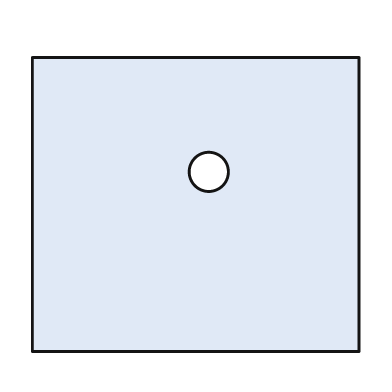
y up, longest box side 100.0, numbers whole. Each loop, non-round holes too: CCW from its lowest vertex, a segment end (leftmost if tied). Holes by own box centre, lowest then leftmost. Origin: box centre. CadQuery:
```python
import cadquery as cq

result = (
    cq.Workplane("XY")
    .moveTo(-50.0, -45.0)
    .lineTo(50.0, -45.0)
    .lineTo(50.0, 45.0)
    .lineTo(-50.0, 45.0)
    .close()
    .moveTo(4.0, 10.0)
    .circle(6.0)
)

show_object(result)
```